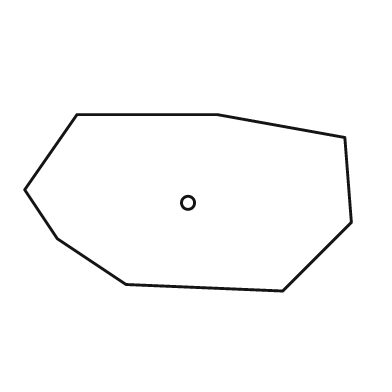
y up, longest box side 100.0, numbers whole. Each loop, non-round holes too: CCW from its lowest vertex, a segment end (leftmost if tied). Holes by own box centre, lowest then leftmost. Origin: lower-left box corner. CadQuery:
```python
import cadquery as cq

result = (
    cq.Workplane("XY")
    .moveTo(79.0, 0.0)
    .lineTo(100.0, 21.0)
    .lineTo(98.0, 47.0)
    .lineTo(59.0, 54.0)
    .lineTo(16.0, 54.0)
    .lineTo(0.0, 31.0)
    .lineTo(10.0, 16.0)
    .lineTo(31.0, 2.0)
    .close()
    .moveTo(50.0, 27.0)
    .circle(2.0)
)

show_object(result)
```